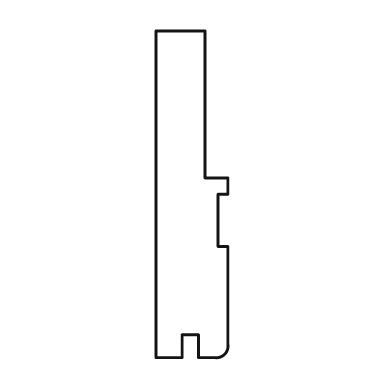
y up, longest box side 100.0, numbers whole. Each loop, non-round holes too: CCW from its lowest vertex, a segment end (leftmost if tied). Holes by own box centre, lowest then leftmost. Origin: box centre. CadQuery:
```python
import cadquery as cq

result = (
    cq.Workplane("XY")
    .moveTo(-11.0, -50.0)
    .lineTo(-3.0, -50.0)
    .lineTo(-3.0, -43.0)
    .lineTo(2.0, -43.0)
    .lineTo(2.0, -50.0)
    .lineTo(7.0, -50.0)
    .threePointArc((10.0, -49.0), (11.0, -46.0))
    .lineTo(11.0, -16.0)
    .lineTo(8.0, -16.0)
    .lineTo(8.0, 0.0)
    .lineTo(11.0, 0.0)
    .lineTo(11.0, 5.0)
    .lineTo(4.0, 5.0)
    .lineTo(4.0, 50.0)
    .lineTo(-11.0, 50.0)
    .close()
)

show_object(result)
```